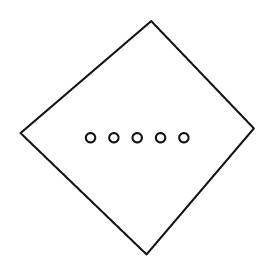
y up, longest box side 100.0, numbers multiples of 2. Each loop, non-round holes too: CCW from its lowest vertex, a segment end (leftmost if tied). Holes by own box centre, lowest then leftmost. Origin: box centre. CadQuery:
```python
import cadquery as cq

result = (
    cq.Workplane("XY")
    .moveTo(4.0, -50.0)
    .lineTo(50.0, 4.0)
    .lineTo(6.0, 50.0)
    .lineTo(-50.0, 2.0)
    .close()
    .moveTo(-20.0, 0.0)
    .circle(2.0)
    .moveTo(-10.0, 0.0)
    .circle(2.0)
    .moveTo(0.0, 0.0)
    .circle(2.0)
    .moveTo(10.0, 0.0)
    .circle(2.0)
    .moveTo(20.0, 0.0)
    .circle(2.0)
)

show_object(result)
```